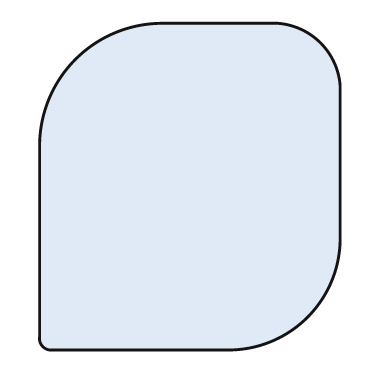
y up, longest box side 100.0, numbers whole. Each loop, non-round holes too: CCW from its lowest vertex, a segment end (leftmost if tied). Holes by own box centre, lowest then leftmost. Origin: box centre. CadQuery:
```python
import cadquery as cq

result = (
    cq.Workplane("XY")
    .moveTo(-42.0, -50.0)
    .lineTo(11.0, -50.0)
    .threePointArc((36.0, -40.0), (46.0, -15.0))
    .lineTo(46.0, 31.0)
    .threePointArc((40.0, 44.0), (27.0, 50.0))
    .lineTo(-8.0, 50.0)
    .threePointArc((-35.0, 39.0), (-46.0, 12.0))
    .lineTo(-46.0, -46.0)
    .threePointArc((-45.0, -49.0), (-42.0, -50.0))
    .close()
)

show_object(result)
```